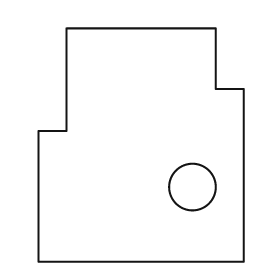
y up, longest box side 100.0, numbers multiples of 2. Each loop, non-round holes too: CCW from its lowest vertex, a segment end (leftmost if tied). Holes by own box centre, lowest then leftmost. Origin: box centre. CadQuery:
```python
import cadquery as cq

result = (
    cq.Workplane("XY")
    .moveTo(-44.0, -50.0)
    .lineTo(44.0, -50.0)
    .lineTo(44.0, 24.0)
    .lineTo(32.0, 24.0)
    .lineTo(32.0, 50.0)
    .lineTo(-32.0, 50.0)
    .lineTo(-32.0, 6.0)
    .lineTo(-44.0, 6.0)
    .close()
    .moveTo(22.0, -18.0)
    .circle(10.0)
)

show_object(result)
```